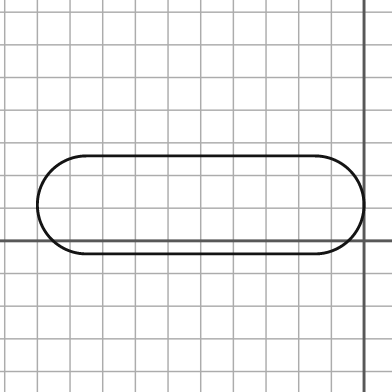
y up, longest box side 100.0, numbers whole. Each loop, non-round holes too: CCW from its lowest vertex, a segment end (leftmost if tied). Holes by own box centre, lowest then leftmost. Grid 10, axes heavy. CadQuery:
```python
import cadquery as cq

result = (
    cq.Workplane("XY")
    .moveTo(-85.0, -4.0)
    .lineTo(-15.0, -4.0)
    .threePointArc((0.0, 11.0), (-15.0, 26.0))
    .lineTo(-85.0, 26.0)
    .threePointArc((-100.0, 11.0), (-85.0, -4.0))
    .close()
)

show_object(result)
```